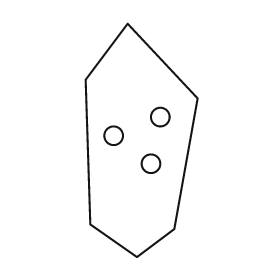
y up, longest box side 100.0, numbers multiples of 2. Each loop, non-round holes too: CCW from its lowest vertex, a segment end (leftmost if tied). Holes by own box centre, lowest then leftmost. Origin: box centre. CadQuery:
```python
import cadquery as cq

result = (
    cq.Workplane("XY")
    .moveTo(-2.0, -50.0)
    .lineTo(14.0, -38.0)
    .lineTo(24.0, 18.0)
    .lineTo(-6.0, 50.0)
    .lineTo(-24.0, 26.0)
    .lineTo(-22.0, -36.0)
    .close()
    .moveTo(4.0, -10.0)
    .circle(4.0)
    .moveTo(-12.0, 2.0)
    .circle(4.0)
    .moveTo(8.0, 10.0)
    .circle(4.0)
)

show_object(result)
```